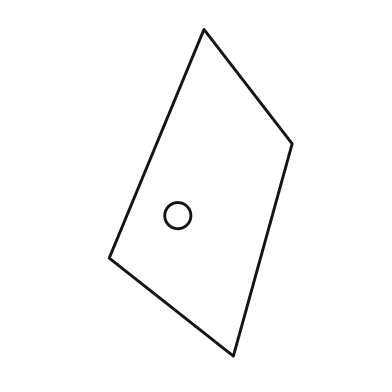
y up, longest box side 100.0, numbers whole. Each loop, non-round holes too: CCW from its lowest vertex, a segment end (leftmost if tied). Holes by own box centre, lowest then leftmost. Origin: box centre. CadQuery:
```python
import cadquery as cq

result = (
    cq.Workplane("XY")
    .moveTo(10.0, -50.0)
    .lineTo(28.0, 15.0)
    .lineTo(1.0, 50.0)
    .lineTo(-28.0, -20.0)
    .close()
    .moveTo(-7.0, -7.0)
    .circle(4.0)
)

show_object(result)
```